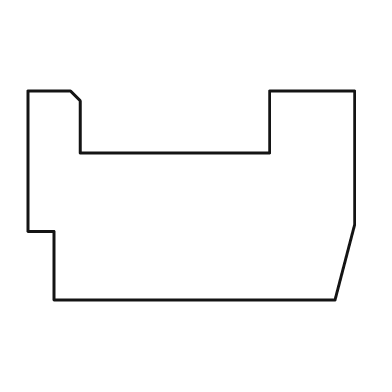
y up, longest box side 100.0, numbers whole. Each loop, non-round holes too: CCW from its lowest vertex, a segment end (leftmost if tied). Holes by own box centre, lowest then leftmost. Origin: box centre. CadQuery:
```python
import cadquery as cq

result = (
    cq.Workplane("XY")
    .moveTo(-42.0, -32.0)
    .lineTo(44.0, -32.0)
    .lineTo(50.0, -9.0)
    .lineTo(50.0, 32.0)
    .lineTo(24.0, 32.0)
    .lineTo(24.0, 13.0)
    .lineTo(-34.0, 13.0)
    .lineTo(-34.0, 29.0)
    .lineTo(-37.0, 32.0)
    .lineTo(-50.0, 32.0)
    .lineTo(-50.0, -11.0)
    .lineTo(-42.0, -11.0)
    .close()
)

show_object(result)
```